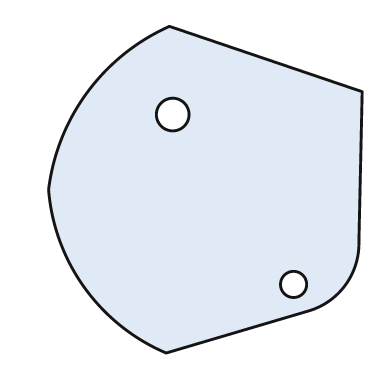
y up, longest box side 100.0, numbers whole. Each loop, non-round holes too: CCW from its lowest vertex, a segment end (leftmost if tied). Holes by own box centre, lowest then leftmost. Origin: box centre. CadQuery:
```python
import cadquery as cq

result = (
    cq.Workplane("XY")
    .moveTo(-12.0, -50.0)
    .lineTo(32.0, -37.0)
    .threePointArc((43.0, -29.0), (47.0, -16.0))
    .lineTo(48.0, 30.0)
    .lineTo(-11.0, 50.0)
    .threePointArc((-36.0, 30.0), (-48.0, 0.0))
    .threePointArc((-37.0, -30.0), (-12.0, -50.0))
    .close()
    .moveTo(27.0, -29.0)
    .circle(4.0)
    .moveTo(-10.0, 23.0)
    .circle(5.0)
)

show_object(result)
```